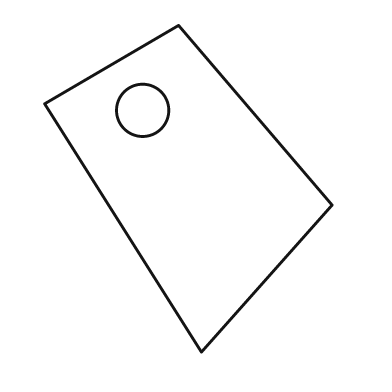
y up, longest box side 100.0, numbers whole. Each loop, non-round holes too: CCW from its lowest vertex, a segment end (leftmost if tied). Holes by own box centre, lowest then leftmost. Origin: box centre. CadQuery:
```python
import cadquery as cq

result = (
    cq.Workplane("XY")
    .moveTo(4.0, -50.0)
    .lineTo(44.0, -5.0)
    .lineTo(-3.0, 50.0)
    .lineTo(-44.0, 26.0)
    .close()
    .moveTo(-14.0, 24.0)
    .circle(8.0)
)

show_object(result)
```